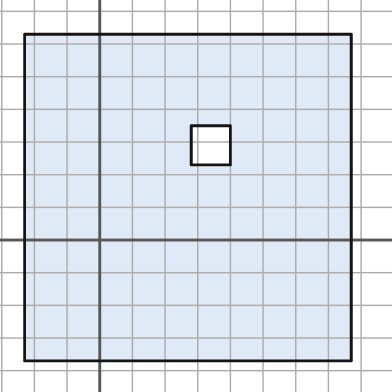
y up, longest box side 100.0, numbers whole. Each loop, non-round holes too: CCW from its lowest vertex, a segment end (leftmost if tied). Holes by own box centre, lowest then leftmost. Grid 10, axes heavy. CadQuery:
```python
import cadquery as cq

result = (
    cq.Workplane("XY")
    .moveTo(-23.0, -37.0)
    .lineTo(77.0, -37.0)
    .lineTo(77.0, 63.0)
    .lineTo(-23.0, 63.0)
    .close()
    .moveTo(28.0, 23.0)
    .lineTo(40.0, 23.0)
    .lineTo(40.0, 35.0)
    .lineTo(28.0, 35.0)
    .close()
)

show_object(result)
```